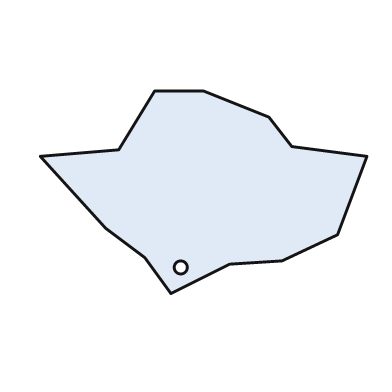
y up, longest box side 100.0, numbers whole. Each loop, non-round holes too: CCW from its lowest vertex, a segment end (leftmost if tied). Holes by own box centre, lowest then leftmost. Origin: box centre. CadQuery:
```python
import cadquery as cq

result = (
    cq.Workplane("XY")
    .moveTo(-10.0, -31.0)
    .lineTo(8.0, -22.0)
    .lineTo(24.0, -21.0)
    .lineTo(41.0, -13.0)
    .lineTo(50.0, 11.0)
    .lineTo(27.0, 14.0)
    .lineTo(20.0, 23.0)
    .lineTo(0.0, 31.0)
    .lineTo(-15.0, 31.0)
    .lineTo(-26.0, 13.0)
    .lineTo(-50.0, 11.0)
    .lineTo(-30.0, -11.0)
    .lineTo(-18.0, -20.0)
    .close()
    .moveTo(-7.0, -23.0)
    .circle(2.0)
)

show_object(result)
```